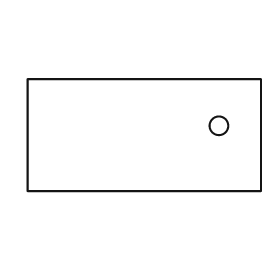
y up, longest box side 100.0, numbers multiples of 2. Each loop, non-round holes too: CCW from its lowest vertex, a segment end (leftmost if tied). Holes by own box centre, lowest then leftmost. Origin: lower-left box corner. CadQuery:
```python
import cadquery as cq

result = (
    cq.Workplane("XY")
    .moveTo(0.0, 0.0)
    .lineTo(100.0, 0.0)
    .lineTo(100.0, 48.0)
    .lineTo(0.0, 48.0)
    .close()
    .moveTo(82.0, 28.0)
    .circle(4.0)
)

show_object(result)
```